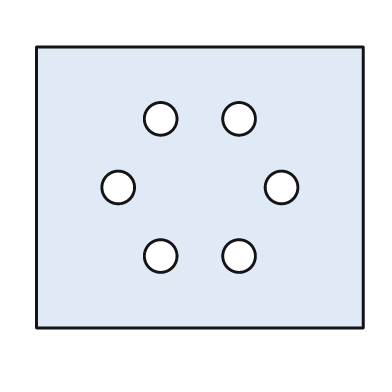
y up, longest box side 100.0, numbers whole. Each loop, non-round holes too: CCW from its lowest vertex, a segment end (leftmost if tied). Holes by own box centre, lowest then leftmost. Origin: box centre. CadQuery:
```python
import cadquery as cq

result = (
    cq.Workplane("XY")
    .moveTo(-50.0, -43.0)
    .lineTo(50.0, -43.0)
    .lineTo(50.0, 43.0)
    .lineTo(-50.0, 43.0)
    .close()
    .moveTo(-12.0, -21.0)
    .circle(5.0)
    .moveTo(12.0, -21.0)
    .circle(5.0)
    .moveTo(-25.0, 0.0)
    .circle(5.0)
    .moveTo(25.0, 0.0)
    .circle(5.0)
    .moveTo(-12.0, 21.0)
    .circle(5.0)
    .moveTo(12.0, 21.0)
    .circle(5.0)
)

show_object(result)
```